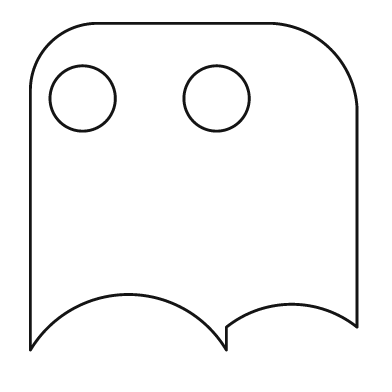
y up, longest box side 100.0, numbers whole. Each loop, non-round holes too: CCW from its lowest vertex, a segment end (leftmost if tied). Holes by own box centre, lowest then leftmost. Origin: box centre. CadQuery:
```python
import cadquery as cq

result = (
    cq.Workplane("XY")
    .moveTo(-50.0, -50.0)
    .threePointArc((-20.0, -33.0), (10.0, -50.0))
    .lineTo(10.0, -43.0)
    .threePointArc((30.0, -36.0), (50.0, -43.0))
    .lineTo(50.0, 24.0)
    .threePointArc((42.0, 42.0), (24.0, 50.0))
    .lineTo(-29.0, 50.0)
    .threePointArc((-44.0, 44.0), (-50.0, 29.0))
    .close()
    .moveTo(-34.0, 27.0)
    .circle(10.0)
    .moveTo(7.0, 27.0)
    .circle(10.0)
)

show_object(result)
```